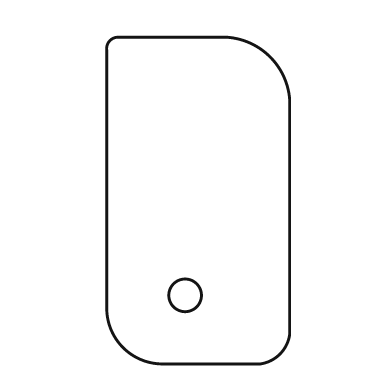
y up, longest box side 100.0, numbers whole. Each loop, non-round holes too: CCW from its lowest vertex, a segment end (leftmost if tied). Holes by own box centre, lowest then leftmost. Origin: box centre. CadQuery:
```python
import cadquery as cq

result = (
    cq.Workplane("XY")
    .moveTo(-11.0, -50.0)
    .lineTo(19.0, -50.0)
    .threePointArc((25.0, -47.0), (28.0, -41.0))
    .lineTo(28.0, 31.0)
    .threePointArc((22.0, 44.0), (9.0, 50.0))
    .lineTo(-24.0, 50.0)
    .threePointArc((-27.0, 49.0), (-28.0, 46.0))
    .lineTo(-28.0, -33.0)
    .threePointArc((-23.0, -45.0), (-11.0, -50.0))
    .close()
    .moveTo(-4.0, -29.0)
    .circle(5.0)
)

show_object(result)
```